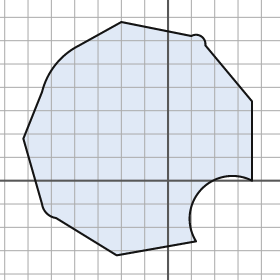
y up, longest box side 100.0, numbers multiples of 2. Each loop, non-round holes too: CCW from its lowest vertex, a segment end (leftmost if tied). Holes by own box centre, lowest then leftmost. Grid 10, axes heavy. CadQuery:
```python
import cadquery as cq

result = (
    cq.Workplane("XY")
    .moveTo(-22.0, -32.0)
    .lineTo(12.0, -26.0)
    .threePointArc((14.0, -4.0), (36.0, 0.0))
    .lineTo(36.0, 34.0)
    .lineTo(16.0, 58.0)
    .threePointArc((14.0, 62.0), (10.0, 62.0))
    .lineTo(-20.0, 68.0)
    .lineTo(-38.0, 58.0)
    .threePointArc((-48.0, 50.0), (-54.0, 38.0))
    .lineTo(-62.0, 18.0)
    .lineTo(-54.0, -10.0)
    .threePointArc((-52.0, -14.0), (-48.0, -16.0))
    .close()
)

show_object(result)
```